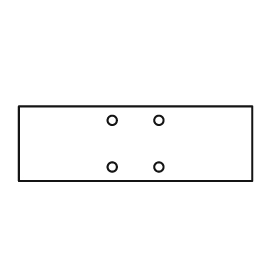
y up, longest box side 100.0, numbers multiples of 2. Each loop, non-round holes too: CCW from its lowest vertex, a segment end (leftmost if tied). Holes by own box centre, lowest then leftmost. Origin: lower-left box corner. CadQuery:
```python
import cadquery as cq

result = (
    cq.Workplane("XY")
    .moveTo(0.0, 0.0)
    .lineTo(100.0, 0.0)
    .lineTo(100.0, 32.0)
    .lineTo(0.0, 32.0)
    .close()
    .moveTo(40.0, 6.0)
    .circle(2.0)
    .moveTo(60.0, 6.0)
    .circle(2.0)
    .moveTo(40.0, 26.0)
    .circle(2.0)
    .moveTo(60.0, 26.0)
    .circle(2.0)
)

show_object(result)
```